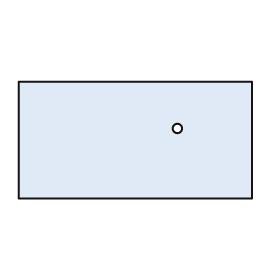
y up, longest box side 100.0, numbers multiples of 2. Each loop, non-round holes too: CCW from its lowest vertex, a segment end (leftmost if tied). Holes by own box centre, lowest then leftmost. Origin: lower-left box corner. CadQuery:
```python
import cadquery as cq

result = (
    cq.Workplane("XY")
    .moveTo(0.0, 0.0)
    .lineTo(100.0, 0.0)
    .lineTo(100.0, 50.0)
    .lineTo(0.0, 50.0)
    .close()
    .moveTo(68.0, 30.0)
    .circle(2.0)
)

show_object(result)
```